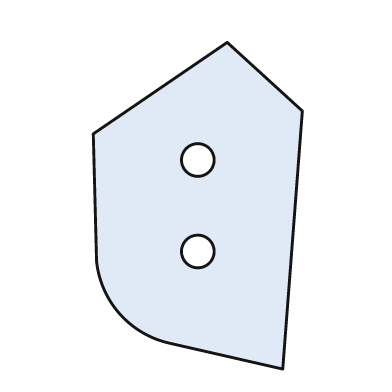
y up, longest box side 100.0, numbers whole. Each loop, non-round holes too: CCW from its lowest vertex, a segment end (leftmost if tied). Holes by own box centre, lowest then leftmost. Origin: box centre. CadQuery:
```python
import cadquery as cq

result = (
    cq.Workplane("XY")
    .moveTo(26.0, -50.0)
    .lineTo(32.0, 29.0)
    .lineTo(9.0, 50.0)
    .lineTo(-32.0, 22.0)
    .lineTo(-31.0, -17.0)
    .threePointArc((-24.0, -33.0), (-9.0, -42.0))
    .close()
    .moveTo(0.0, -14.0)
    .circle(5.0)
    .moveTo(0.0, 14.0)
    .circle(5.0)
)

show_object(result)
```